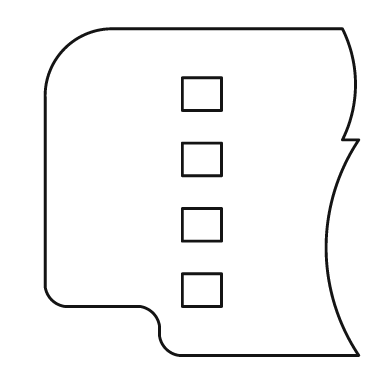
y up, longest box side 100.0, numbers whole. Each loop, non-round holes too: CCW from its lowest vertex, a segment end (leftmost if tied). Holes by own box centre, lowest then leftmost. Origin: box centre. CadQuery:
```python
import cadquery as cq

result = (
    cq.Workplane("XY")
    .moveTo(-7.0, -50.0)
    .lineTo(48.0, -50.0)
    .threePointArc((38.0, -17.0), (48.0, 16.0))
    .lineTo(43.0, 16.0)
    .threePointArc((47.0, 33.0), (43.0, 50.0))
    .lineTo(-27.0, 50.0)
    .threePointArc((-42.0, 44.0), (-48.0, 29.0))
    .lineTo(-48.0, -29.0)
    .threePointArc((-46.0, -33.0), (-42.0, -35.0))
    .lineTo(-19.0, -35.0)
    .threePointArc((-15.0, -37.0), (-13.0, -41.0))
    .lineTo(-13.0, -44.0)
    .threePointArc((-11.0, -48.0), (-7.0, -50.0))
    .close()
    .moveTo(-6.0, -35.0)
    .lineTo(6.0, -35.0)
    .lineTo(6.0, -25.0)
    .lineTo(-6.0, -25.0)
    .close()
    .moveTo(-6.0, -15.0)
    .lineTo(6.0, -15.0)
    .lineTo(6.0, -5.0)
    .lineTo(-6.0, -5.0)
    .close()
    .moveTo(-6.0, 5.0)
    .lineTo(6.0, 5.0)
    .lineTo(6.0, 15.0)
    .lineTo(-6.0, 15.0)
    .close()
    .moveTo(-6.0, 25.0)
    .lineTo(6.0, 25.0)
    .lineTo(6.0, 35.0)
    .lineTo(-6.0, 35.0)
    .close()
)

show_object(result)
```